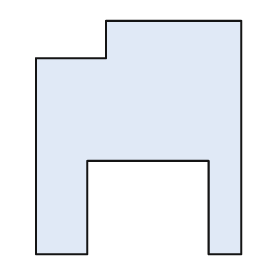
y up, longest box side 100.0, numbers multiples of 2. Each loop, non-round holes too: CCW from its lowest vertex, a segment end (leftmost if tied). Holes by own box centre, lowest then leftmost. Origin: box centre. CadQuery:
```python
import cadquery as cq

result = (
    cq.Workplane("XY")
    .moveTo(-44.0, -50.0)
    .lineTo(-22.0, -50.0)
    .lineTo(-22.0, -10.0)
    .lineTo(30.0, -10.0)
    .lineTo(30.0, -50.0)
    .lineTo(44.0, -50.0)
    .lineTo(44.0, 50.0)
    .lineTo(-14.0, 50.0)
    .lineTo(-14.0, 34.0)
    .lineTo(-44.0, 34.0)
    .close()
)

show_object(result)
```